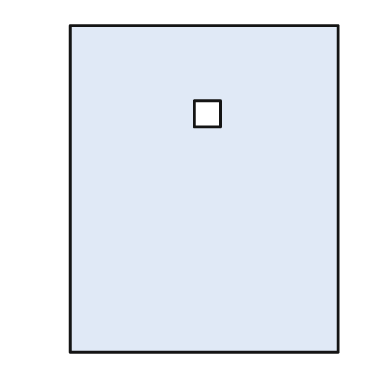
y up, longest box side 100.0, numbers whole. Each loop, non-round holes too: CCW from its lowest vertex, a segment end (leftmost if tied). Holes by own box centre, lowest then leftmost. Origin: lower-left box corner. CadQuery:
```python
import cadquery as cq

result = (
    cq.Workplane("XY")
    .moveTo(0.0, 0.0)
    .lineTo(82.0, 0.0)
    .lineTo(82.0, 100.0)
    .lineTo(0.0, 100.0)
    .close()
    .moveTo(38.0, 69.0)
    .lineTo(46.0, 69.0)
    .lineTo(46.0, 77.0)
    .lineTo(38.0, 77.0)
    .close()
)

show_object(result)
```